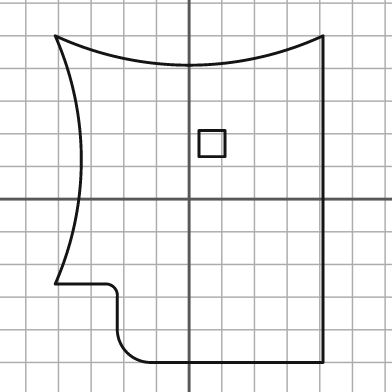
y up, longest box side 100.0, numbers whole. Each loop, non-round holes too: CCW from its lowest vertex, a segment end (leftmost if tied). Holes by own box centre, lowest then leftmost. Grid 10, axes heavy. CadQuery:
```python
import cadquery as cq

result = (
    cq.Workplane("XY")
    .moveTo(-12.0, -50.0)
    .lineTo(41.0, -50.0)
    .lineTo(41.0, 50.0)
    .threePointArc((0.0, 41.0), (-41.0, 50.0))
    .threePointArc((-33.0, 12.0), (-41.0, -26.0))
    .lineTo(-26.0, -26.0)
    .threePointArc((-23.0, -27.0), (-22.0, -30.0))
    .lineTo(-22.0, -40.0)
    .threePointArc((-19.0, -47.0), (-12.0, -50.0))
    .close()
    .moveTo(3.0, 13.0)
    .lineTo(11.0, 13.0)
    .lineTo(11.0, 21.0)
    .lineTo(3.0, 21.0)
    .close()
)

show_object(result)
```